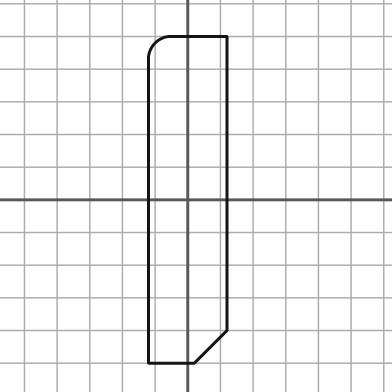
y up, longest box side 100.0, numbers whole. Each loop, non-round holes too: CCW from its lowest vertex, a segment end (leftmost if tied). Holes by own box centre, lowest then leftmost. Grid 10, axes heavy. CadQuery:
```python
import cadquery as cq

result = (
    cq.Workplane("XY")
    .moveTo(-12.0, -50.0)
    .lineTo(2.0, -50.0)
    .lineTo(12.0, -40.0)
    .lineTo(12.0, 50.0)
    .lineTo(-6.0, 50.0)
    .threePointArc((-10.0, 48.0), (-12.0, 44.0))
    .close()
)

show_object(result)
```